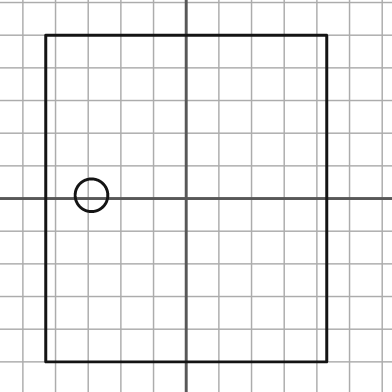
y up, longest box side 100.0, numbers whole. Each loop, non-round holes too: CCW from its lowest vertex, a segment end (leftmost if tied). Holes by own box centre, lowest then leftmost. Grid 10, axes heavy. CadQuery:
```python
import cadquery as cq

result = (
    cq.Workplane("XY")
    .moveTo(-43.0, -50.0)
    .lineTo(43.0, -50.0)
    .lineTo(43.0, 50.0)
    .lineTo(-43.0, 50.0)
    .close()
    .moveTo(-29.0, 1.0)
    .circle(5.0)
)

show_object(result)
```